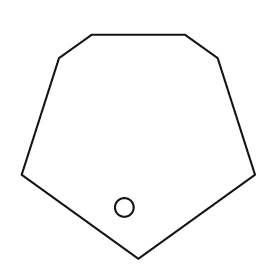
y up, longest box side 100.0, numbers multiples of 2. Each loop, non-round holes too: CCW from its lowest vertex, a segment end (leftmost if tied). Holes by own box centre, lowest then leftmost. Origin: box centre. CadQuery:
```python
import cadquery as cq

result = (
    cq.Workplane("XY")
    .moveTo(0.0, -48.0)
    .lineTo(50.0, -12.0)
    .lineTo(34.0, 38.0)
    .lineTo(20.0, 48.0)
    .lineTo(-20.0, 48.0)
    .lineTo(-34.0, 38.0)
    .lineTo(-50.0, -12.0)
    .close()
    .moveTo(-6.0, -26.0)
    .circle(4.0)
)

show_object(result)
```